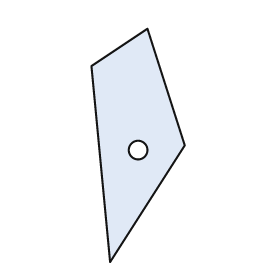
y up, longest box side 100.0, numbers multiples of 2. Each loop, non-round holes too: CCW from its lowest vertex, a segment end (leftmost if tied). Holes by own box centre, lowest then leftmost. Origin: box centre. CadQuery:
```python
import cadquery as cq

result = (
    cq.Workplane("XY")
    .moveTo(-12.0, -50.0)
    .lineTo(20.0, 0.0)
    .lineTo(4.0, 50.0)
    .lineTo(-20.0, 34.0)
    .close()
    .moveTo(0.0, -2.0)
    .circle(4.0)
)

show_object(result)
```